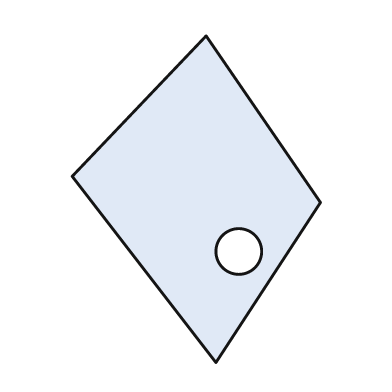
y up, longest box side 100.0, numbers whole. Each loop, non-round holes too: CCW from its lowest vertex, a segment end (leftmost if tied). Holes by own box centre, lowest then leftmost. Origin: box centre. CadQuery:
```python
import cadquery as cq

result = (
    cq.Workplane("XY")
    .moveTo(6.0, -50.0)
    .lineTo(38.0, -1.0)
    .lineTo(3.0, 50.0)
    .lineTo(-38.0, 7.0)
    .close()
    .moveTo(13.0, -16.0)
    .circle(7.0)
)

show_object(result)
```